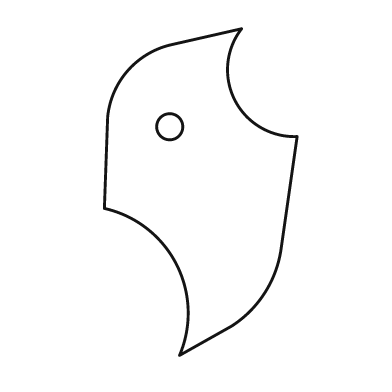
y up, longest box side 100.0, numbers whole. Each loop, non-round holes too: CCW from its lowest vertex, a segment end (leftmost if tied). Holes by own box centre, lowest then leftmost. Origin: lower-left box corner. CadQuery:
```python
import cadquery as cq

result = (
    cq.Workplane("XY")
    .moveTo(23.0, 0.0)
    .lineTo(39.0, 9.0)
    .threePointArc((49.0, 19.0), (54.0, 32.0))
    .lineTo(59.0, 67.0)
    .threePointArc((40.0, 78.0), (42.0, 100.0))
    .lineTo(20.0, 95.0)
    .threePointArc((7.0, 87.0), (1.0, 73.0))
    .lineTo(0.0, 45.0)
    .threePointArc((22.0, 28.0), (23.0, 0.0))
    .close()
    .moveTo(20.0, 70.0)
    .circle(4.0)
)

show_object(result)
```